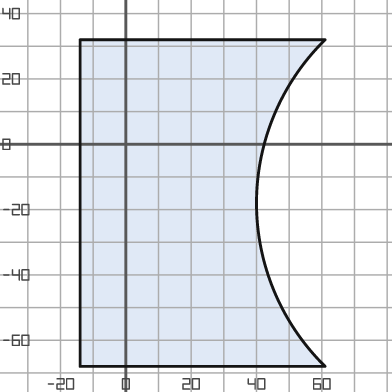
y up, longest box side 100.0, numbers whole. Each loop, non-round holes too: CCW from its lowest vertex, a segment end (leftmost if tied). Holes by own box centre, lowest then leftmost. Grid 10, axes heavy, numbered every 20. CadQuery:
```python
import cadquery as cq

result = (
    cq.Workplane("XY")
    .moveTo(-14.0, -68.0)
    .lineTo(61.0, -68.0)
    .threePointArc((40.0, -18.0), (61.0, 32.0))
    .lineTo(-14.0, 32.0)
    .close()
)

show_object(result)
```